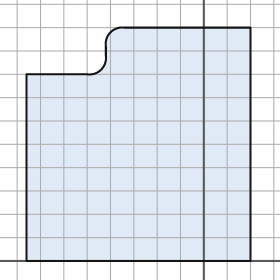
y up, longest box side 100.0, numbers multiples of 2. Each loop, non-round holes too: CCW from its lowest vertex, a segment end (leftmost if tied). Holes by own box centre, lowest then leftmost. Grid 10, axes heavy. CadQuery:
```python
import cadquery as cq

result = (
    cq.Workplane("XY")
    .moveTo(-76.0, 0.0)
    .lineTo(20.0, 0.0)
    .lineTo(20.0, 100.0)
    .lineTo(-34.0, 100.0)
    .threePointArc((-40.0, 98.0), (-42.0, 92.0))
    .lineTo(-42.0, 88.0)
    .threePointArc((-44.0, 82.0), (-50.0, 80.0))
    .lineTo(-76.0, 80.0)
    .close()
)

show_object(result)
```